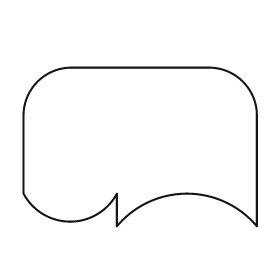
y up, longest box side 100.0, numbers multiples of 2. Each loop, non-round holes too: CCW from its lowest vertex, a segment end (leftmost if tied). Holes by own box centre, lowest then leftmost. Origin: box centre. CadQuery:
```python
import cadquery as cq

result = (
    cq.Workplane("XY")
    .moveTo(-10.0, -34.0)
    .threePointArc((20.0, -20.0), (50.0, -34.0))
    .lineTo(50.0, 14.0)
    .threePointArc((44.0, 28.0), (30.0, 34.0))
    .lineTo(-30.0, 34.0)
    .threePointArc((-44.0, 28.0), (-50.0, 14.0))
    .lineTo(-50.0, -20.0)
    .threePointArc((-30.0, -32.0), (-10.0, -20.0))
    .close()
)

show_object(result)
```